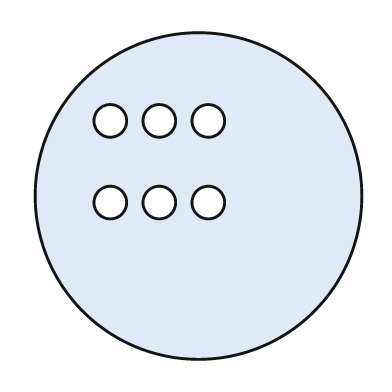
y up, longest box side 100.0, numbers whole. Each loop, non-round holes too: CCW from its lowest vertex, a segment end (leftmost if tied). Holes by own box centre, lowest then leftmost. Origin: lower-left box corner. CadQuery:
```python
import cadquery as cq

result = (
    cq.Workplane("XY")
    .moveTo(50.0, 50.0)
    .circle(50.0)
    .moveTo(23.0, 48.0)
    .circle(5.0)
    .moveTo(38.0, 48.0)
    .circle(5.0)
    .moveTo(53.0, 48.0)
    .circle(5.0)
    .moveTo(23.0, 73.0)
    .circle(5.0)
    .moveTo(38.0, 73.0)
    .circle(5.0)
    .moveTo(53.0, 73.0)
    .circle(5.0)
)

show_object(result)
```